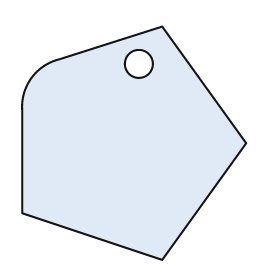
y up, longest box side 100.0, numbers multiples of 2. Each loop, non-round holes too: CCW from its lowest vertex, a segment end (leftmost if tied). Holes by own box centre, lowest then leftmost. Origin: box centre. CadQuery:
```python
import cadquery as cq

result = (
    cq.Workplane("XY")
    .moveTo(12.0, -50.0)
    .lineTo(48.0, 0.0)
    .lineTo(12.0, 50.0)
    .lineTo(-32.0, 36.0)
    .threePointArc((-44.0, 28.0), (-48.0, 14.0))
    .lineTo(-48.0, -30.0)
    .close()
    .moveTo(2.0, 34.0)
    .circle(6.0)
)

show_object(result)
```